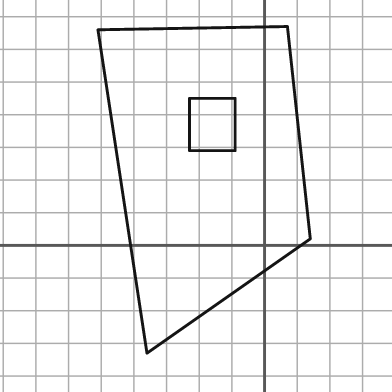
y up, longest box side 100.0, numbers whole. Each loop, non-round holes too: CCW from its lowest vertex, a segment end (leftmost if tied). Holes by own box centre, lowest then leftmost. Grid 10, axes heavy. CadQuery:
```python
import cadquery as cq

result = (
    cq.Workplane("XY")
    .moveTo(-36.0, -33.0)
    .lineTo(14.0, 2.0)
    .lineTo(7.0, 67.0)
    .lineTo(-51.0, 66.0)
    .close()
    .moveTo(-23.0, 29.0)
    .lineTo(-9.0, 29.0)
    .lineTo(-9.0, 45.0)
    .lineTo(-23.0, 45.0)
    .close()
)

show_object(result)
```